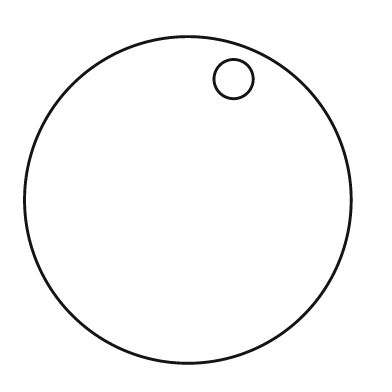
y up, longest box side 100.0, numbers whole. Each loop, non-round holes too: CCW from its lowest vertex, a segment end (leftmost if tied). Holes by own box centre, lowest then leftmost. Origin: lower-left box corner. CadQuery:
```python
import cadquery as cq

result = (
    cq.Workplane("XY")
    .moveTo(50.0, 50.0)
    .circle(50.0)
    .moveTo(64.0, 87.0)
    .circle(6.0)
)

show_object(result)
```